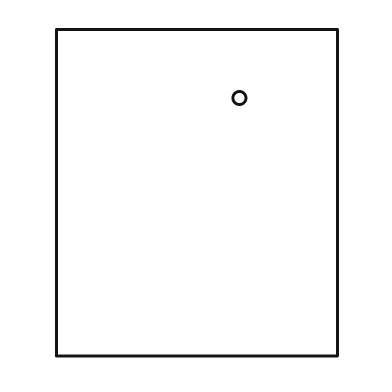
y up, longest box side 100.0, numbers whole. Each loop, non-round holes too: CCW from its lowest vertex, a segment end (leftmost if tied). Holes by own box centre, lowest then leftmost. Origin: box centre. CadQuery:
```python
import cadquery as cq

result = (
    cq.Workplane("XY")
    .moveTo(-43.0, -50.0)
    .lineTo(43.0, -50.0)
    .lineTo(43.0, 50.0)
    .lineTo(-43.0, 50.0)
    .close()
    .moveTo(13.0, 29.0)
    .circle(2.0)
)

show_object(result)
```